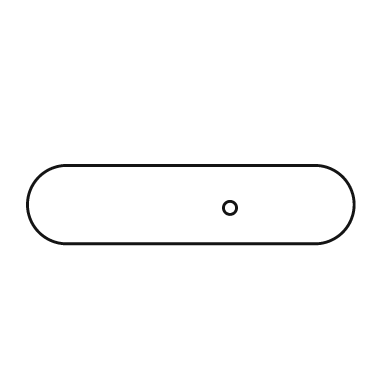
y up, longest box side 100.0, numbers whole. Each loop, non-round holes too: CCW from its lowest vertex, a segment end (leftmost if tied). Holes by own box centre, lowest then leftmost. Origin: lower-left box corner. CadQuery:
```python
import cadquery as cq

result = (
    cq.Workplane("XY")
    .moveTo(12.0, 0.0)
    .lineTo(88.0, 0.0)
    .threePointArc((100.0, 12.0), (88.0, 24.0))
    .lineTo(12.0, 24.0)
    .threePointArc((0.0, 12.0), (12.0, 0.0))
    .close()
    .moveTo(62.0, 11.0)
    .circle(2.0)
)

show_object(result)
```